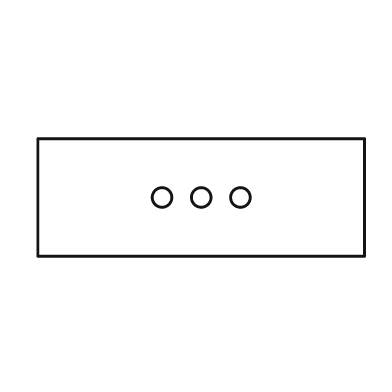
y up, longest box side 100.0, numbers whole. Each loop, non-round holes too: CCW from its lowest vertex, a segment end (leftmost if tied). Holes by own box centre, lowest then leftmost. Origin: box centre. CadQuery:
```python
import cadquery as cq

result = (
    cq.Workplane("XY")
    .moveTo(-50.0, -18.0)
    .lineTo(50.0, -18.0)
    .lineTo(50.0, 18.0)
    .lineTo(-50.0, 18.0)
    .close()
    .moveTo(-12.0, 0.0)
    .circle(3.0)
    .moveTo(0.0, 0.0)
    .circle(3.0)
    .moveTo(12.0, 0.0)
    .circle(3.0)
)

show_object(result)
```